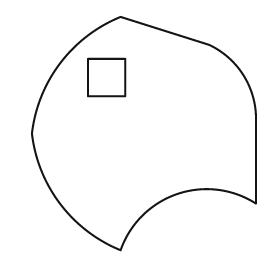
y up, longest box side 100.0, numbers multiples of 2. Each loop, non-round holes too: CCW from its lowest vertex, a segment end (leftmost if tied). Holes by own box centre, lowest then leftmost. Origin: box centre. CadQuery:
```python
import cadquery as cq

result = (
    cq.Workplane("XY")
    .moveTo(-10.0, -50.0)
    .threePointArc((14.0, -26.0), (48.0, -30.0))
    .lineTo(48.0, 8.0)
    .threePointArc((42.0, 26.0), (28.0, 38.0))
    .lineTo(-10.0, 50.0)
    .threePointArc((-36.0, 30.0), (-48.0, 0.0))
    .threePointArc((-36.0, -30.0), (-10.0, -50.0))
    .close()
    .moveTo(-24.0, 16.0)
    .lineTo(-8.0, 16.0)
    .lineTo(-8.0, 32.0)
    .lineTo(-24.0, 32.0)
    .close()
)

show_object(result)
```